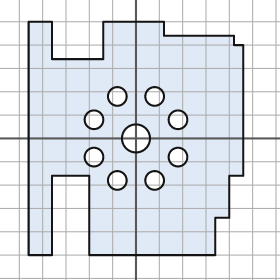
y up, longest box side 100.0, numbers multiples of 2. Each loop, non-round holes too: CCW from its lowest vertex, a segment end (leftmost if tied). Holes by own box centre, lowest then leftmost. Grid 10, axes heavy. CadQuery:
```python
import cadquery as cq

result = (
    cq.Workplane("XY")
    .moveTo(-46.0, -50.0)
    .lineTo(-36.0, -50.0)
    .lineTo(-36.0, -16.0)
    .lineTo(-20.0, -16.0)
    .lineTo(-20.0, -50.0)
    .lineTo(34.0, -50.0)
    .lineTo(34.0, -34.0)
    .lineTo(40.0, -34.0)
    .lineTo(40.0, -16.0)
    .lineTo(46.0, -16.0)
    .lineTo(46.0, 40.0)
    .lineTo(42.0, 40.0)
    .lineTo(42.0, 44.0)
    .lineTo(12.0, 44.0)
    .lineTo(12.0, 50.0)
    .lineTo(-14.0, 50.0)
    .lineTo(-14.0, 34.0)
    .lineTo(-36.0, 34.0)
    .lineTo(-36.0, 50.0)
    .lineTo(-46.0, 50.0)
    .close()
    .moveTo(-8.0, -18.0)
    .circle(4.0)
    .moveTo(8.0, -18.0)
    .circle(4.0)
    .moveTo(-18.0, -8.0)
    .circle(4.0)
    .moveTo(18.0, -8.0)
    .circle(4.0)
    .moveTo(0.0, 0.0)
    .circle(6.0)
    .moveTo(-18.0, 8.0)
    .circle(4.0)
    .moveTo(18.0, 8.0)
    .circle(4.0)
    .moveTo(-8.0, 18.0)
    .circle(4.0)
    .moveTo(8.0, 18.0)
    .circle(4.0)
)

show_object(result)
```